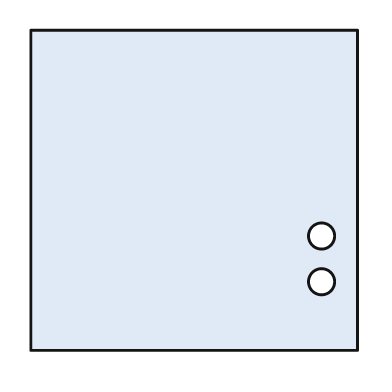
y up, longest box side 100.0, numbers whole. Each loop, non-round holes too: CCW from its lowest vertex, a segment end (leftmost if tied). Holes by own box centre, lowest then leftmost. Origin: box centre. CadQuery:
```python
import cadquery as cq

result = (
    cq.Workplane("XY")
    .moveTo(-50.0, -49.0)
    .lineTo(50.0, -49.0)
    .lineTo(50.0, 49.0)
    .lineTo(-50.0, 49.0)
    .close()
    .moveTo(39.0, -28.0)
    .circle(4.0)
    .moveTo(39.0, -14.0)
    .circle(4.0)
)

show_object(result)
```